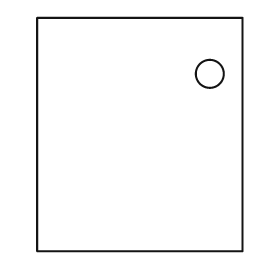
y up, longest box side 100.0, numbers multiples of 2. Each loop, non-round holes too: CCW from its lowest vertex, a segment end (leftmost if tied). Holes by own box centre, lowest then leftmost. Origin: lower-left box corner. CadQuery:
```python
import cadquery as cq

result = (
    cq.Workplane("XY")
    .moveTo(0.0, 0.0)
    .lineTo(88.0, 0.0)
    .lineTo(88.0, 100.0)
    .lineTo(0.0, 100.0)
    .close()
    .moveTo(74.0, 76.0)
    .circle(6.0)
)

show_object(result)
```